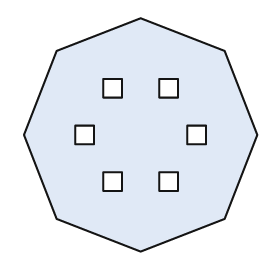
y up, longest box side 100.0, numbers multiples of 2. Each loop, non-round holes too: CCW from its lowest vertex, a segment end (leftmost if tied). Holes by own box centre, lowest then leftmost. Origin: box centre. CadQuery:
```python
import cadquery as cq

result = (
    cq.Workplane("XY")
    .moveTo(0.0, -50.0)
    .lineTo(36.0, -36.0)
    .lineTo(50.0, 0.0)
    .lineTo(36.0, 36.0)
    .lineTo(0.0, 50.0)
    .lineTo(-36.0, 36.0)
    .lineTo(-50.0, 0.0)
    .lineTo(-36.0, -36.0)
    .close()
    .moveTo(-16.0, -24.0)
    .lineTo(-8.0, -24.0)
    .lineTo(-8.0, -16.0)
    .lineTo(-16.0, -16.0)
    .close()
    .moveTo(8.0, -24.0)
    .lineTo(16.0, -24.0)
    .lineTo(16.0, -16.0)
    .lineTo(8.0, -16.0)
    .close()
    .moveTo(-28.0, -4.0)
    .lineTo(-20.0, -4.0)
    .lineTo(-20.0, 4.0)
    .lineTo(-28.0, 4.0)
    .close()
    .moveTo(20.0, -4.0)
    .lineTo(28.0, -4.0)
    .lineTo(28.0, 4.0)
    .lineTo(20.0, 4.0)
    .close()
    .moveTo(-16.0, 16.0)
    .lineTo(-8.0, 16.0)
    .lineTo(-8.0, 24.0)
    .lineTo(-16.0, 24.0)
    .close()
    .moveTo(8.0, 16.0)
    .lineTo(16.0, 16.0)
    .lineTo(16.0, 24.0)
    .lineTo(8.0, 24.0)
    .close()
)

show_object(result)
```